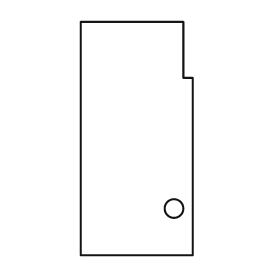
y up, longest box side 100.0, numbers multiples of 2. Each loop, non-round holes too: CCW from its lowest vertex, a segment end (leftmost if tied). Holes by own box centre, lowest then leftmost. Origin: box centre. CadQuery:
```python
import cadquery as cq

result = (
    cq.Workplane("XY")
    .moveTo(-24.0, -50.0)
    .lineTo(24.0, -50.0)
    .lineTo(24.0, 26.0)
    .lineTo(20.0, 26.0)
    .lineTo(20.0, 50.0)
    .lineTo(-24.0, 50.0)
    .close()
    .moveTo(16.0, -30.0)
    .circle(4.0)
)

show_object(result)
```